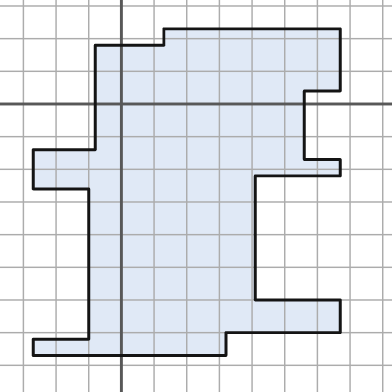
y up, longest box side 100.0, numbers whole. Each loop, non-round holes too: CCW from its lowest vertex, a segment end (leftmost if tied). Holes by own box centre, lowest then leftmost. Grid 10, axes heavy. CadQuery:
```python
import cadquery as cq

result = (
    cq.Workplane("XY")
    .moveTo(-27.0, -77.0)
    .lineTo(32.0, -77.0)
    .lineTo(32.0, -70.0)
    .lineTo(67.0, -70.0)
    .lineTo(67.0, -60.0)
    .lineTo(41.0, -60.0)
    .lineTo(41.0, -22.0)
    .lineTo(67.0, -22.0)
    .lineTo(67.0, -17.0)
    .lineTo(56.0, -17.0)
    .lineTo(56.0, 4.0)
    .lineTo(67.0, 4.0)
    .lineTo(67.0, 23.0)
    .lineTo(13.0, 23.0)
    .lineTo(13.0, 18.0)
    .lineTo(-8.0, 18.0)
    .lineTo(-8.0, -14.0)
    .lineTo(-27.0, -14.0)
    .lineTo(-27.0, -26.0)
    .lineTo(-10.0, -26.0)
    .lineTo(-10.0, -72.0)
    .lineTo(-27.0, -72.0)
    .close()
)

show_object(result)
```